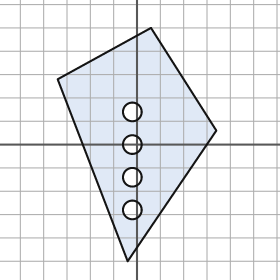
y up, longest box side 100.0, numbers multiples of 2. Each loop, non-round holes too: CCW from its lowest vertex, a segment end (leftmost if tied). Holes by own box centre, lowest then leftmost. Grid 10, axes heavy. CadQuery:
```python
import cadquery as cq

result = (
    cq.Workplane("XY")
    .moveTo(-4.0, -50.0)
    .lineTo(34.0, 6.0)
    .lineTo(6.0, 50.0)
    .lineTo(-34.0, 28.0)
    .close()
    .moveTo(-2.0, -28.0)
    .circle(4.0)
    .moveTo(-2.0, -14.0)
    .circle(4.0)
    .moveTo(-2.0, 0.0)
    .circle(4.0)
    .moveTo(-2.0, 14.0)
    .circle(4.0)
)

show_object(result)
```